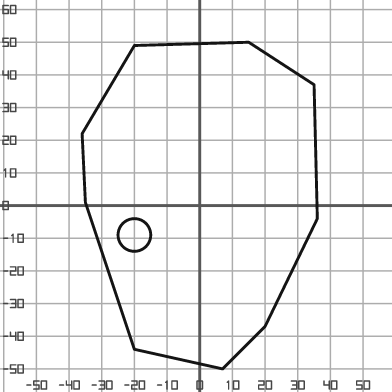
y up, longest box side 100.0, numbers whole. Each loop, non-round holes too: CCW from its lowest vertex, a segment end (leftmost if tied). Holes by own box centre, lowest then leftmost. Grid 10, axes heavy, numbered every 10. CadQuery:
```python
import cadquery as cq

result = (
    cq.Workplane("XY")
    .moveTo(7.0, -50.0)
    .lineTo(20.0, -37.0)
    .lineTo(36.0, -4.0)
    .lineTo(35.0, 37.0)
    .lineTo(15.0, 50.0)
    .lineTo(-20.0, 49.0)
    .lineTo(-36.0, 22.0)
    .lineTo(-35.0, 1.0)
    .lineTo(-20.0, -44.0)
    .close()
    .moveTo(-20.0, -9.0)
    .circle(5.0)
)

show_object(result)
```